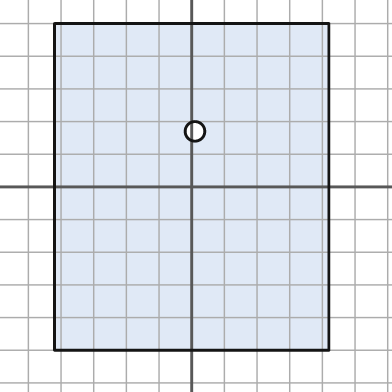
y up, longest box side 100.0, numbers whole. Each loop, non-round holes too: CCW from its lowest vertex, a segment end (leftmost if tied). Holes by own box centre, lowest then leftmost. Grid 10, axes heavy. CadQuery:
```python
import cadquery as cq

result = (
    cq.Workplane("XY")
    .moveTo(-42.0, -50.0)
    .lineTo(42.0, -50.0)
    .lineTo(42.0, 50.0)
    .lineTo(-42.0, 50.0)
    .close()
    .moveTo(1.0, 17.0)
    .circle(3.0)
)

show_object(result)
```